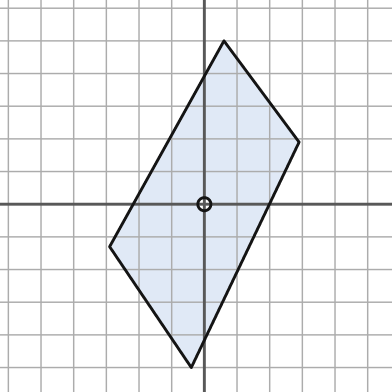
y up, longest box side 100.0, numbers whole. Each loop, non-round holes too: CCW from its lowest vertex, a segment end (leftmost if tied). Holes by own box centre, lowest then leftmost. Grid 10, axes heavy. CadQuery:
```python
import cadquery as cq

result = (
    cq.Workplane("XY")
    .moveTo(-4.0, -50.0)
    .lineTo(29.0, 19.0)
    .lineTo(6.0, 50.0)
    .lineTo(-29.0, -13.0)
    .close()
    .moveTo(0.0, 0.0)
    .circle(2.0)
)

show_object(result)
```